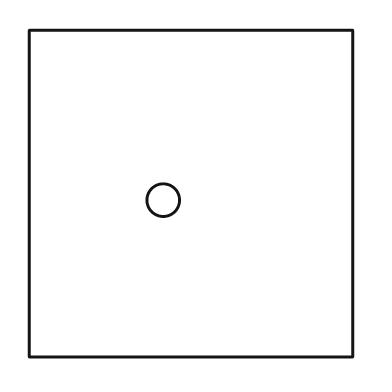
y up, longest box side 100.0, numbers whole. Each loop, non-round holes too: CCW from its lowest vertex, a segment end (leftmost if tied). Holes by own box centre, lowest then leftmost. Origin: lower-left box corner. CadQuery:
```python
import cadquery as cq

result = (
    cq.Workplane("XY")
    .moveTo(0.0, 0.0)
    .lineTo(99.0, 0.0)
    .lineTo(99.0, 100.0)
    .lineTo(0.0, 100.0)
    .close()
    .moveTo(41.0, 48.0)
    .circle(5.0)
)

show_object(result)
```